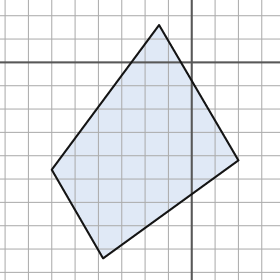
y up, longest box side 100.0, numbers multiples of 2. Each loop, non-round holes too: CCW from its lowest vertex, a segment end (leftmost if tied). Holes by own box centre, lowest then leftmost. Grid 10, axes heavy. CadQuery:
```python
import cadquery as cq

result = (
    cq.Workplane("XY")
    .moveTo(-38.0, -84.0)
    .lineTo(20.0, -42.0)
    .lineTo(-14.0, 16.0)
    .lineTo(-60.0, -46.0)
    .close()
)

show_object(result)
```